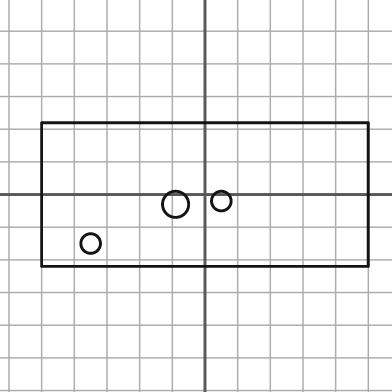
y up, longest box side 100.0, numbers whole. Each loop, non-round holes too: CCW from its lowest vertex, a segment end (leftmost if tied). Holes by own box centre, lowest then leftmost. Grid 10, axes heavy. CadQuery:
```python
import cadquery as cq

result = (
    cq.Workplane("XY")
    .moveTo(-50.0, -22.0)
    .lineTo(50.0, -22.0)
    .lineTo(50.0, 22.0)
    .lineTo(-50.0, 22.0)
    .close()
    .moveTo(-35.0, -15.0)
    .circle(3.0)
    .moveTo(-9.0, -3.0)
    .circle(4.0)
    .moveTo(5.0, -2.0)
    .circle(3.0)
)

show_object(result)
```